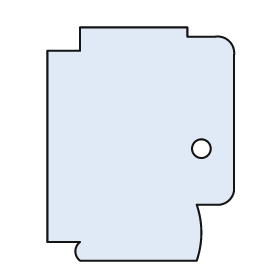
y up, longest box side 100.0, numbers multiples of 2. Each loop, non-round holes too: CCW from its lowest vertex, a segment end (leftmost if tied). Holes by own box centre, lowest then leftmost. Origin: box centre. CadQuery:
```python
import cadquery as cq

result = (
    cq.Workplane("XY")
    .moveTo(-26.0, -50.0)
    .lineTo(24.0, -50.0)
    .threePointArc((26.0, -38.0), (24.0, -26.0))
    .lineTo(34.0, -26.0)
    .threePointArc((38.0, -24.0), (40.0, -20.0))
    .lineTo(40.0, 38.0)
    .threePointArc((38.0, 44.0), (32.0, 46.0))
    .lineTo(20.0, 46.0)
    .lineTo(20.0, 50.0)
    .lineTo(-26.0, 50.0)
    .lineTo(-26.0, 40.0)
    .lineTo(-40.0, 40.0)
    .lineTo(-40.0, -42.0)
    .lineTo(-26.0, -42.0)
    .threePointArc((-28.0, -46.0), (-26.0, -50.0))
    .close()
    .moveTo(26.0, -2.0)
    .circle(4.0)
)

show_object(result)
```